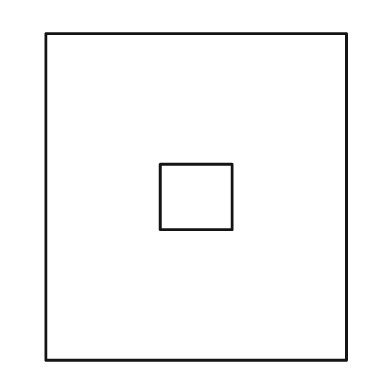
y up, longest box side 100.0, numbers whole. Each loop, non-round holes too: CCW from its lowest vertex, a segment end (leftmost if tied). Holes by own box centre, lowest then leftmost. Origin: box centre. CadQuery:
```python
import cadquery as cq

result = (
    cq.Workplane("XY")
    .moveTo(-46.0, -50.0)
    .lineTo(46.0, -50.0)
    .lineTo(46.0, 50.0)
    .lineTo(-46.0, 50.0)
    .close()
    .moveTo(-11.0, -10.0)
    .lineTo(11.0, -10.0)
    .lineTo(11.0, 10.0)
    .lineTo(-11.0, 10.0)
    .close()
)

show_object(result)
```